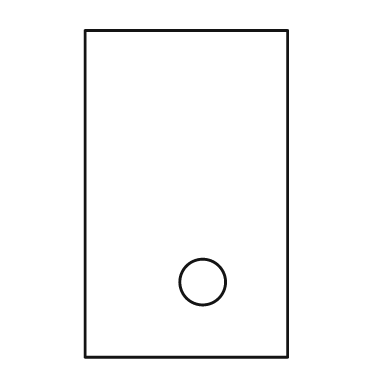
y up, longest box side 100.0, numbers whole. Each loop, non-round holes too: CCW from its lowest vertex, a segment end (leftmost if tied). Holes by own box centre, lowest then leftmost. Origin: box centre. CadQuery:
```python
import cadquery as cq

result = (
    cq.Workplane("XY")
    .moveTo(-31.0, -50.0)
    .lineTo(31.0, -50.0)
    .lineTo(31.0, 50.0)
    .lineTo(-31.0, 50.0)
    .close()
    .moveTo(5.0, -27.0)
    .circle(7.0)
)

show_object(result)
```